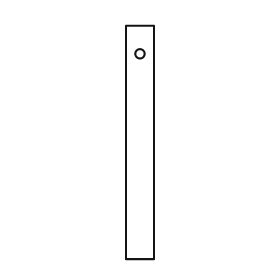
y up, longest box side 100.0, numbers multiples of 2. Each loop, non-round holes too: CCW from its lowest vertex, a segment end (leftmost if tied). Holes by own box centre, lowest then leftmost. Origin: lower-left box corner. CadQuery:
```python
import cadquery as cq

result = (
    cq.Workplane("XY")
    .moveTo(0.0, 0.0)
    .lineTo(12.0, 0.0)
    .lineTo(12.0, 100.0)
    .lineTo(0.0, 100.0)
    .close()
    .moveTo(6.0, 88.0)
    .circle(2.0)
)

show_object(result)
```